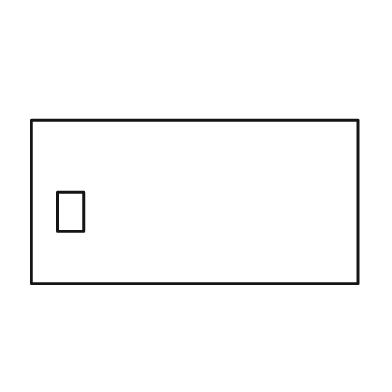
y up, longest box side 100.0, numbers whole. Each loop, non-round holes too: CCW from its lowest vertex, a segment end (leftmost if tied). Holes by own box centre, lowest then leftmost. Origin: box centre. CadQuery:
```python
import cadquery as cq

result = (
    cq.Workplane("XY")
    .moveTo(-50.0, -25.0)
    .lineTo(50.0, -25.0)
    .lineTo(50.0, 25.0)
    .lineTo(-50.0, 25.0)
    .close()
    .moveTo(-42.0, -9.0)
    .lineTo(-34.0, -9.0)
    .lineTo(-34.0, 3.0)
    .lineTo(-42.0, 3.0)
    .close()
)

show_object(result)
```